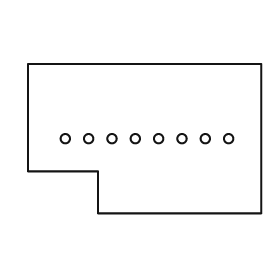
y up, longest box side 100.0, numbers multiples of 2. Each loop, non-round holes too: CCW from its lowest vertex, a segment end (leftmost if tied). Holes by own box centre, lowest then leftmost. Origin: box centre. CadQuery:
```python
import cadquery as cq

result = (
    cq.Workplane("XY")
    .moveTo(-20.0, -32.0)
    .lineTo(50.0, -32.0)
    .lineTo(50.0, 32.0)
    .lineTo(-50.0, 32.0)
    .lineTo(-50.0, -14.0)
    .lineTo(-20.0, -14.0)
    .close()
    .moveTo(-34.0, 0.0)
    .circle(2.0)
    .moveTo(-24.0, 0.0)
    .circle(2.0)
    .moveTo(-14.0, 0.0)
    .circle(2.0)
    .moveTo(-4.0, 0.0)
    .circle(2.0)
    .moveTo(6.0, 0.0)
    .circle(2.0)
    .moveTo(16.0, 0.0)
    .circle(2.0)
    .moveTo(26.0, 0.0)
    .circle(2.0)
    .moveTo(36.0, 0.0)
    .circle(2.0)
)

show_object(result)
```